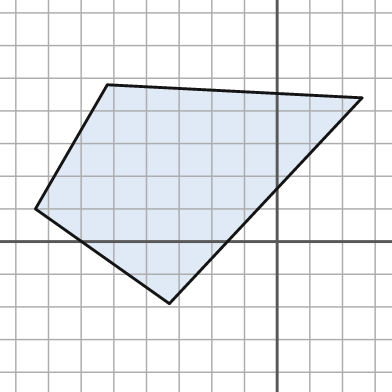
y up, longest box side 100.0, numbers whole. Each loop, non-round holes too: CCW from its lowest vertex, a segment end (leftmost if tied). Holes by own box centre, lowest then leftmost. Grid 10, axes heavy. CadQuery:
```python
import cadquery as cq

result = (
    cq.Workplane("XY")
    .moveTo(-33.0, -19.0)
    .lineTo(26.0, 44.0)
    .lineTo(-52.0, 48.0)
    .lineTo(-74.0, 10.0)
    .close()
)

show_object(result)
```